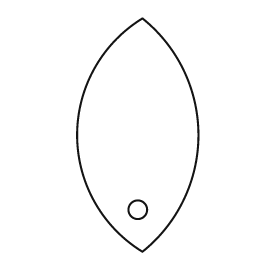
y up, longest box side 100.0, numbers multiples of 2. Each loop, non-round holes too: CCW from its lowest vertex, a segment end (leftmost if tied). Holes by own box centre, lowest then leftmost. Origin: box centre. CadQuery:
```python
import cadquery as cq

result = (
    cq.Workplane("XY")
    .moveTo(2.0, -50.0)
    .threePointArc((26.0, 0.0), (2.0, 50.0))
    .threePointArc((-26.0, 0.0), (2.0, -50.0))
    .close()
    .moveTo(0.0, -32.0)
    .circle(4.0)
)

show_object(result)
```